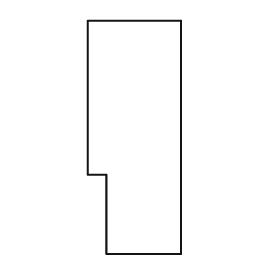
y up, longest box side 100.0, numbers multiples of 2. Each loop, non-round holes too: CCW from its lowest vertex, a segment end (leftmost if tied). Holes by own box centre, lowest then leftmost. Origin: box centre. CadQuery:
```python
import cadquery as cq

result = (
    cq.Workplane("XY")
    .moveTo(-12.0, -50.0)
    .lineTo(20.0, -50.0)
    .lineTo(20.0, 50.0)
    .lineTo(-20.0, 50.0)
    .lineTo(-20.0, -16.0)
    .lineTo(-12.0, -16.0)
    .close()
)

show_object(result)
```